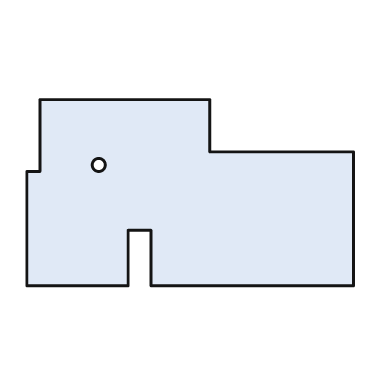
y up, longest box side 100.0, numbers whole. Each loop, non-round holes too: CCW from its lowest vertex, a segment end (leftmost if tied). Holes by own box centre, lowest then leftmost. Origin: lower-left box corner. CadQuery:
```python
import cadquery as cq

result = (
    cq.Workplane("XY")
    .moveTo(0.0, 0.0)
    .lineTo(31.0, 0.0)
    .lineTo(31.0, 17.0)
    .lineTo(38.0, 17.0)
    .lineTo(38.0, 0.0)
    .lineTo(100.0, 0.0)
    .lineTo(100.0, 41.0)
    .lineTo(56.0, 41.0)
    .lineTo(56.0, 57.0)
    .lineTo(4.0, 57.0)
    .lineTo(4.0, 35.0)
    .lineTo(0.0, 35.0)
    .close()
    .moveTo(22.0, 37.0)
    .circle(2.0)
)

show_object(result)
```